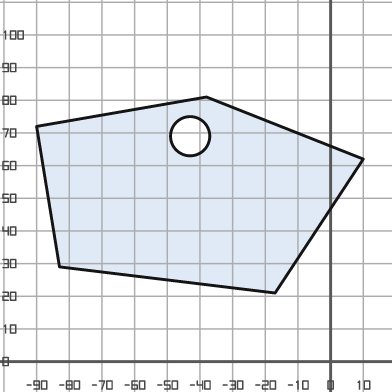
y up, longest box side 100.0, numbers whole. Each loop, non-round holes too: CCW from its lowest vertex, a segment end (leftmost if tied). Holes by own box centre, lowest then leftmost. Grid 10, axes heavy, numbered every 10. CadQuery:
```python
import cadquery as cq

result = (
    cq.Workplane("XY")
    .moveTo(-17.0, 21.0)
    .lineTo(10.0, 62.0)
    .lineTo(-38.0, 81.0)
    .lineTo(-90.0, 72.0)
    .lineTo(-83.0, 29.0)
    .close()
    .moveTo(-43.0, 69.0)
    .circle(6.0)
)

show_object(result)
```